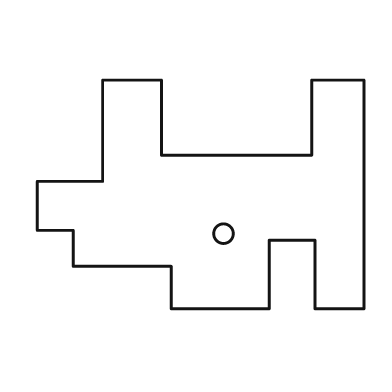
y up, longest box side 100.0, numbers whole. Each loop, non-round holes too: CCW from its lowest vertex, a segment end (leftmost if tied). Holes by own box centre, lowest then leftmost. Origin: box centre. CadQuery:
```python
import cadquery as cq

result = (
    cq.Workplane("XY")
    .moveTo(-9.0, -35.0)
    .lineTo(21.0, -35.0)
    .lineTo(21.0, -14.0)
    .lineTo(35.0, -14.0)
    .lineTo(35.0, -35.0)
    .lineTo(50.0, -35.0)
    .lineTo(50.0, 35.0)
    .lineTo(34.0, 35.0)
    .lineTo(34.0, 12.0)
    .lineTo(-12.0, 12.0)
    .lineTo(-12.0, 35.0)
    .lineTo(-30.0, 35.0)
    .lineTo(-30.0, 4.0)
    .lineTo(-50.0, 4.0)
    .lineTo(-50.0, -11.0)
    .lineTo(-39.0, -11.0)
    .lineTo(-39.0, -22.0)
    .lineTo(-9.0, -22.0)
    .close()
    .moveTo(7.0, -12.0)
    .circle(3.0)
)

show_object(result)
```